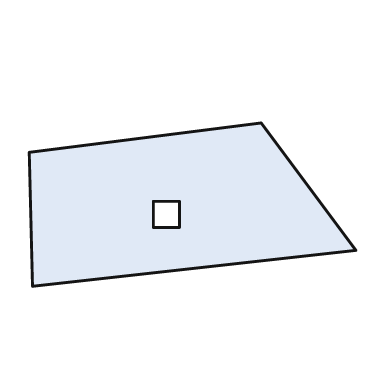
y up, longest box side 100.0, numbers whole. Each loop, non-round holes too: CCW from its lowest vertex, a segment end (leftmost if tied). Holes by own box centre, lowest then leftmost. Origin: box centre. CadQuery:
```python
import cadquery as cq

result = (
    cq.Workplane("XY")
    .moveTo(-49.0, -25.0)
    .lineTo(50.0, -14.0)
    .lineTo(21.0, 25.0)
    .lineTo(-50.0, 16.0)
    .close()
    .moveTo(-12.0, -7.0)
    .lineTo(-4.0, -7.0)
    .lineTo(-4.0, 1.0)
    .lineTo(-12.0, 1.0)
    .close()
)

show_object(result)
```